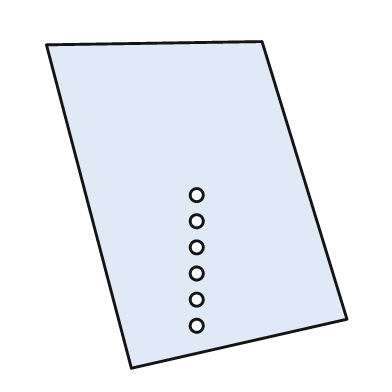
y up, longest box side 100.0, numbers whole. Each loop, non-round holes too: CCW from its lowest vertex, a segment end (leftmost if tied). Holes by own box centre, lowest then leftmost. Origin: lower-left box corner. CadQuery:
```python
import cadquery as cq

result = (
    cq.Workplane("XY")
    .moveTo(26.0, 0.0)
    .lineTo(92.0, 15.0)
    .lineTo(66.0, 100.0)
    .lineTo(0.0, 99.0)
    .close()
    .moveTo(46.0, 13.0)
    .circle(2.0)
    .moveTo(46.0, 21.0)
    .circle(2.0)
    .moveTo(46.0, 29.0)
    .circle(2.0)
    .moveTo(46.0, 37.0)
    .circle(2.0)
    .moveTo(46.0, 45.0)
    .circle(2.0)
    .moveTo(46.0, 53.0)
    .circle(2.0)
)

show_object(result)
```